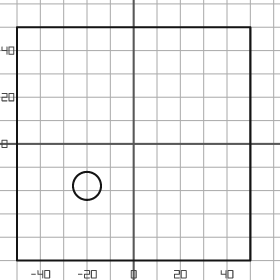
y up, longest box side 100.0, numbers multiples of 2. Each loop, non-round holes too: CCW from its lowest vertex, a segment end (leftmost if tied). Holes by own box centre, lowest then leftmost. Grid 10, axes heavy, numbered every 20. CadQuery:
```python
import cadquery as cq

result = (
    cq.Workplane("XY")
    .moveTo(-50.0, -50.0)
    .lineTo(50.0, -50.0)
    .lineTo(50.0, 50.0)
    .lineTo(-50.0, 50.0)
    .close()
    .moveTo(-20.0, -18.0)
    .circle(6.0)
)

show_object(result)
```